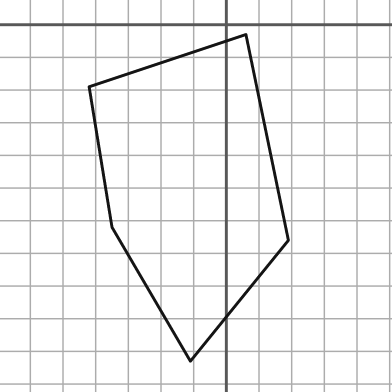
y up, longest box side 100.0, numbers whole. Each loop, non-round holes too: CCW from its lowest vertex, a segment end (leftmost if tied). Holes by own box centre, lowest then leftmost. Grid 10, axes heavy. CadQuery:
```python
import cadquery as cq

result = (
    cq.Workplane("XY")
    .moveTo(-11.0, -103.0)
    .lineTo(19.0, -66.0)
    .lineTo(6.0, -3.0)
    .lineTo(-42.0, -19.0)
    .lineTo(-35.0, -62.0)
    .close()
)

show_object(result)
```